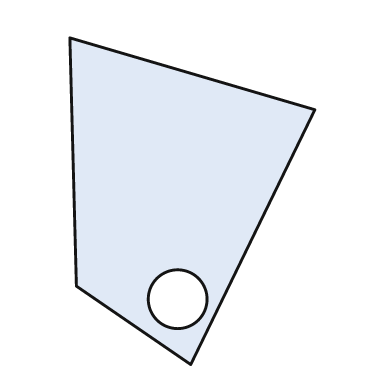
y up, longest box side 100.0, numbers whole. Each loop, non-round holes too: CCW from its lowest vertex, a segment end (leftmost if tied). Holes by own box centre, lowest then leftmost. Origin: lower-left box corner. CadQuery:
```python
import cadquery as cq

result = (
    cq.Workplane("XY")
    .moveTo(37.0, 0.0)
    .lineTo(75.0, 78.0)
    .lineTo(0.0, 100.0)
    .lineTo(2.0, 24.0)
    .close()
    .moveTo(33.0, 20.0)
    .circle(9.0)
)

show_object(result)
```